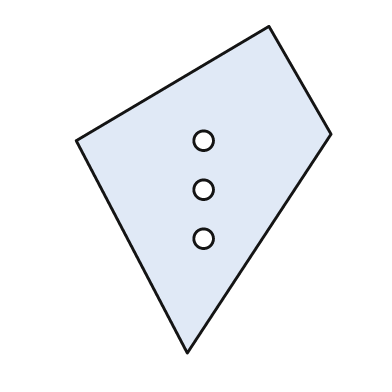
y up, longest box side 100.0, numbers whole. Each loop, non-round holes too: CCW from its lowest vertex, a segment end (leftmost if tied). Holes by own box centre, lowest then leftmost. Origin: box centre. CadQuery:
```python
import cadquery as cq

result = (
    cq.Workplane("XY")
    .moveTo(-5.0, -50.0)
    .lineTo(39.0, 17.0)
    .lineTo(20.0, 50.0)
    .lineTo(-39.0, 15.0)
    .close()
    .moveTo(0.0, -15.0)
    .circle(3.0)
    .moveTo(0.0, 0.0)
    .circle(3.0)
    .moveTo(0.0, 15.0)
    .circle(3.0)
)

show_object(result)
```